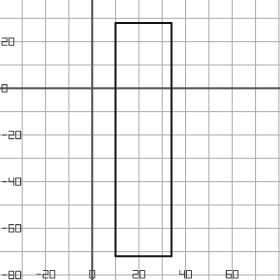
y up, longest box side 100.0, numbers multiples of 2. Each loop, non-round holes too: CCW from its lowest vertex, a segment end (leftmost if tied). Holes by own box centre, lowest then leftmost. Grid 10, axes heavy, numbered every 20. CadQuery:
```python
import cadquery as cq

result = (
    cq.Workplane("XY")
    .moveTo(10.0, -72.0)
    .lineTo(34.0, -72.0)
    .lineTo(34.0, 28.0)
    .lineTo(10.0, 28.0)
    .close()
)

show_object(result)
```